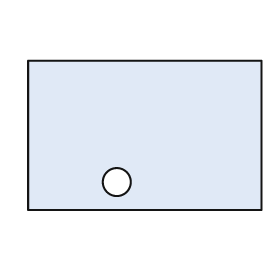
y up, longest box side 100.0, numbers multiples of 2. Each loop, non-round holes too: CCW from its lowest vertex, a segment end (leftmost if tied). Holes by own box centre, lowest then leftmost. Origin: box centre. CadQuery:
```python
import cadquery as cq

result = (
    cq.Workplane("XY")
    .moveTo(-50.0, -32.0)
    .lineTo(50.0, -32.0)
    .lineTo(50.0, 32.0)
    .lineTo(-50.0, 32.0)
    .close()
    .moveTo(-12.0, -20.0)
    .circle(6.0)
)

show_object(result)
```